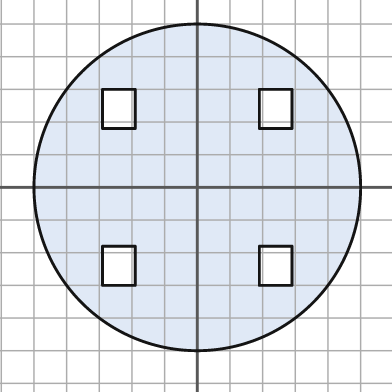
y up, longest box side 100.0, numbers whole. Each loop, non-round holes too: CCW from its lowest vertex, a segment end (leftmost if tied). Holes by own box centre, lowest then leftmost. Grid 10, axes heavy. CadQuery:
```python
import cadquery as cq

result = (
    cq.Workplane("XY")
    .moveTo(0.0, 0.0)
    .circle(50.0)
    .moveTo(-29.0, -30.0)
    .lineTo(-19.0, -30.0)
    .lineTo(-19.0, -18.0)
    .lineTo(-29.0, -18.0)
    .close()
    .moveTo(19.0, -30.0)
    .lineTo(29.0, -30.0)
    .lineTo(29.0, -18.0)
    .lineTo(19.0, -18.0)
    .close()
    .moveTo(-29.0, 18.0)
    .lineTo(-19.0, 18.0)
    .lineTo(-19.0, 30.0)
    .lineTo(-29.0, 30.0)
    .close()
    .moveTo(19.0, 18.0)
    .lineTo(29.0, 18.0)
    .lineTo(29.0, 30.0)
    .lineTo(19.0, 30.0)
    .close()
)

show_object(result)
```